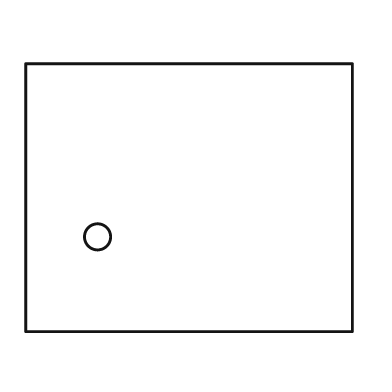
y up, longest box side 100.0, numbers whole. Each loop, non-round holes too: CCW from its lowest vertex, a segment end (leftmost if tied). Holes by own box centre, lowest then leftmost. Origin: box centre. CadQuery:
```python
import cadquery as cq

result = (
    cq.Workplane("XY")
    .moveTo(-50.0, -41.0)
    .lineTo(50.0, -41.0)
    .lineTo(50.0, 41.0)
    .lineTo(-50.0, 41.0)
    .close()
    .moveTo(-28.0, -12.0)
    .circle(4.0)
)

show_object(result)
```